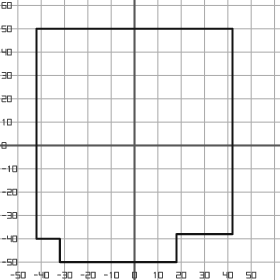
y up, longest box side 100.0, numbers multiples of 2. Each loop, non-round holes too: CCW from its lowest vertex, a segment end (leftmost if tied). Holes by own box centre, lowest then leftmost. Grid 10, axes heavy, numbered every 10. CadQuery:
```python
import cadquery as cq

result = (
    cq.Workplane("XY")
    .moveTo(-32.0, -50.0)
    .lineTo(18.0, -50.0)
    .lineTo(18.0, -38.0)
    .lineTo(42.0, -38.0)
    .lineTo(42.0, 50.0)
    .lineTo(-42.0, 50.0)
    .lineTo(-42.0, -40.0)
    .lineTo(-32.0, -40.0)
    .close()
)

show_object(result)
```